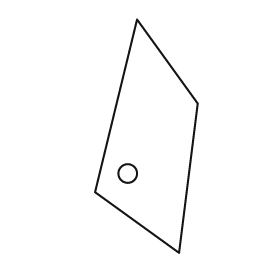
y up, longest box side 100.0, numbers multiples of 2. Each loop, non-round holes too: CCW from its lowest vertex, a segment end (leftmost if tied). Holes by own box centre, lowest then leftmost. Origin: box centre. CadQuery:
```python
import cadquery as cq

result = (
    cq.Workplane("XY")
    .moveTo(14.0, -50.0)
    .lineTo(22.0, 14.0)
    .lineTo(-4.0, 50.0)
    .lineTo(-22.0, -24.0)
    .close()
    .moveTo(-8.0, -16.0)
    .circle(4.0)
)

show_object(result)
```